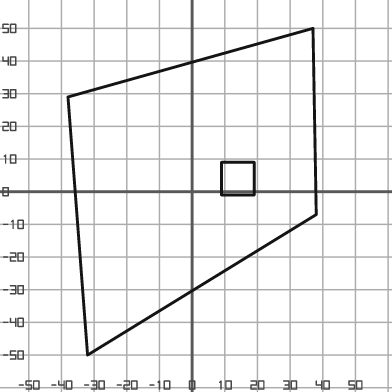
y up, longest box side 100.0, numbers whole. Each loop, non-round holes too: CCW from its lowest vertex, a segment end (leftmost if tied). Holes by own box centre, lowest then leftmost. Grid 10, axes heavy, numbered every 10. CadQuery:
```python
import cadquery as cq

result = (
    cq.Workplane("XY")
    .moveTo(-32.0, -50.0)
    .lineTo(38.0, -7.0)
    .lineTo(37.0, 50.0)
    .lineTo(-38.0, 29.0)
    .close()
    .moveTo(9.0, -1.0)
    .lineTo(19.0, -1.0)
    .lineTo(19.0, 9.0)
    .lineTo(9.0, 9.0)
    .close()
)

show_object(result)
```